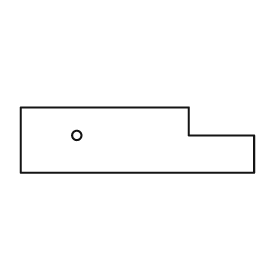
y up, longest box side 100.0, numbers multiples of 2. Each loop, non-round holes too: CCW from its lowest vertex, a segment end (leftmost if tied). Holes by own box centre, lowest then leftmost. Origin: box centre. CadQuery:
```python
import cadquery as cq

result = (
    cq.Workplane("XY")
    .moveTo(-50.0, -14.0)
    .lineTo(50.0, -14.0)
    .lineTo(50.0, 2.0)
    .lineTo(22.0, 2.0)
    .lineTo(22.0, 14.0)
    .lineTo(-50.0, 14.0)
    .close()
    .moveTo(-26.0, 2.0)
    .circle(2.0)
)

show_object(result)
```